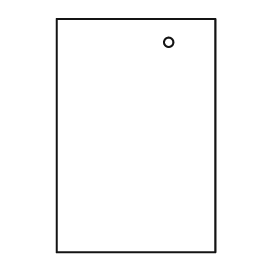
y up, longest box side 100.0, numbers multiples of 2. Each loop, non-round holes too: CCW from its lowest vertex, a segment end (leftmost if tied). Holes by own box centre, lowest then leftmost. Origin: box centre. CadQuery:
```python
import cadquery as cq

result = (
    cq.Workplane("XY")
    .moveTo(-34.0, -50.0)
    .lineTo(34.0, -50.0)
    .lineTo(34.0, 50.0)
    .lineTo(-34.0, 50.0)
    .close()
    .moveTo(14.0, 40.0)
    .circle(2.0)
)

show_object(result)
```